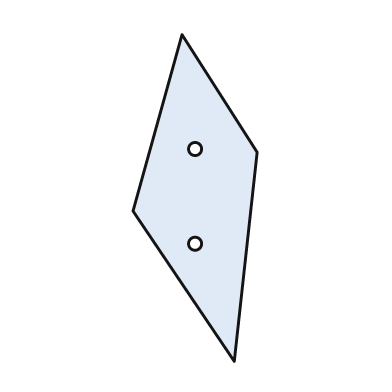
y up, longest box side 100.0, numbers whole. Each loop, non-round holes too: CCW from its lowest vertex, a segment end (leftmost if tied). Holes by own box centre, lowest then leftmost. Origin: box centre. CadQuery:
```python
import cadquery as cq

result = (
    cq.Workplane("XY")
    .moveTo(12.0, -50.0)
    .lineTo(19.0, 14.0)
    .lineTo(-4.0, 50.0)
    .lineTo(-19.0, -4.0)
    .close()
    .moveTo(0.0, -14.0)
    .circle(2.0)
    .moveTo(0.0, 15.0)
    .circle(2.0)
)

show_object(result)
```